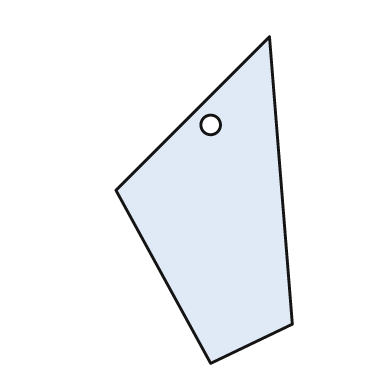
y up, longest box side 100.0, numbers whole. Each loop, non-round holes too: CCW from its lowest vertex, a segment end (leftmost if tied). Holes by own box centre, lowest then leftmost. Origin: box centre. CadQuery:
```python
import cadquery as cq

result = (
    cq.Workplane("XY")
    .moveTo(2.0, -50.0)
    .lineTo(27.0, -38.0)
    .lineTo(20.0, 50.0)
    .lineTo(-27.0, 3.0)
    .close()
    .moveTo(2.0, 23.0)
    .circle(3.0)
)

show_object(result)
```